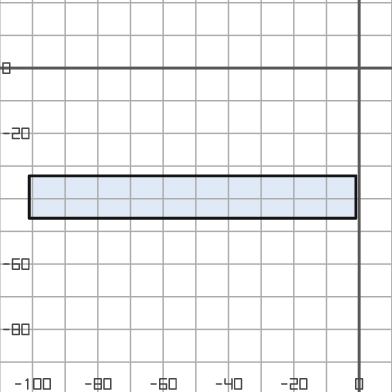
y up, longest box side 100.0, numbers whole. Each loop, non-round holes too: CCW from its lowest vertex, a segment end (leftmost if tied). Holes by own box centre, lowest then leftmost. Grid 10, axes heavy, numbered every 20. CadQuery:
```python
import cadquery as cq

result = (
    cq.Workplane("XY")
    .moveTo(-101.0, -46.0)
    .lineTo(-1.0, -46.0)
    .lineTo(-1.0, -33.0)
    .lineTo(-101.0, -33.0)
    .close()
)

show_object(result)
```